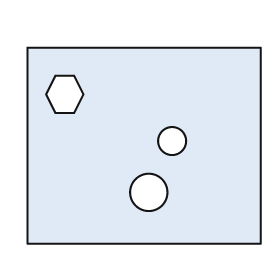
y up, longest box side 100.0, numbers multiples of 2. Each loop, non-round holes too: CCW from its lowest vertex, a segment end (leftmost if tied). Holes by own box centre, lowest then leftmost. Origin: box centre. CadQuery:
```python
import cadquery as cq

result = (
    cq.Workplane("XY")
    .moveTo(-50.0, -42.0)
    .lineTo(50.0, -42.0)
    .lineTo(50.0, 42.0)
    .lineTo(-50.0, 42.0)
    .close()
    .moveTo(2.0, -20.0)
    .circle(8.0)
    .moveTo(12.0, 2.0)
    .circle(6.0)
    .moveTo(-38.0, 14.0)
    .lineTo(-30.0, 14.0)
    .lineTo(-26.0, 22.0)
    .lineTo(-30.0, 30.0)
    .lineTo(-38.0, 30.0)
    .lineTo(-42.0, 22.0)
    .close()
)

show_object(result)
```